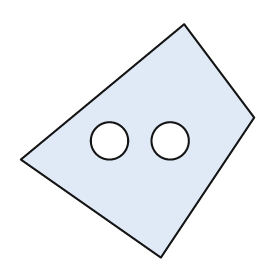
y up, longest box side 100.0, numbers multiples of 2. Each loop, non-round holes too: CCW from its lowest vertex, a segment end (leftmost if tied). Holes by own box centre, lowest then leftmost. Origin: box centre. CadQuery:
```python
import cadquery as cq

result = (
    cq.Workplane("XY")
    .moveTo(10.0, -50.0)
    .lineTo(50.0, 10.0)
    .lineTo(20.0, 50.0)
    .lineTo(-50.0, -8.0)
    .close()
    .moveTo(-12.0, 0.0)
    .circle(8.0)
    .moveTo(14.0, 0.0)
    .circle(8.0)
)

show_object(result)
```